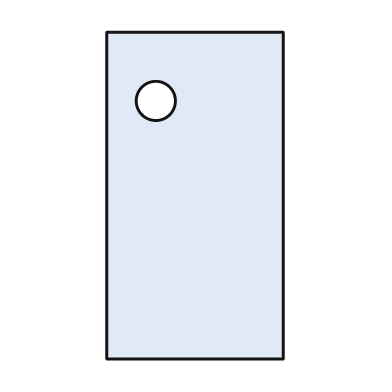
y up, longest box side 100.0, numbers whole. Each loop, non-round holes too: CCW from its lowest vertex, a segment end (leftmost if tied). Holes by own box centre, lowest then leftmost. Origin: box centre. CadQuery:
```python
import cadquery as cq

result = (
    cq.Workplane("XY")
    .moveTo(-27.0, -50.0)
    .lineTo(27.0, -50.0)
    .lineTo(27.0, 50.0)
    .lineTo(-27.0, 50.0)
    .close()
    .moveTo(-12.0, 29.0)
    .circle(6.0)
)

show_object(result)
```